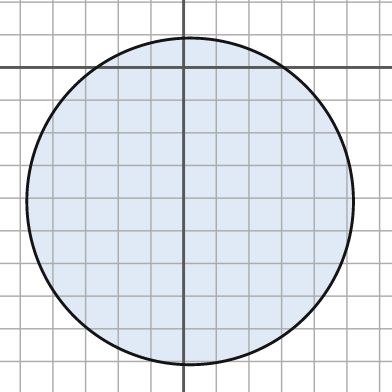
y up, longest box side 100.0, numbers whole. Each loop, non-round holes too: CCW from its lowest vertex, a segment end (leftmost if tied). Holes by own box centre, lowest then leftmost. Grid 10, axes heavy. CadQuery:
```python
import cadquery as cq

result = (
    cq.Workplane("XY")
    .moveTo(2.0, -41.0)
    .circle(50.0)
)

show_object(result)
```